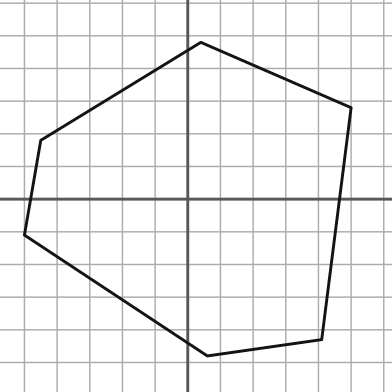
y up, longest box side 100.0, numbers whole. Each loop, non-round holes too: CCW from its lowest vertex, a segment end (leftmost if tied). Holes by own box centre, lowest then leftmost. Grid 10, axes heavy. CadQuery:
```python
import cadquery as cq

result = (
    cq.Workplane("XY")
    .moveTo(6.0, -48.0)
    .lineTo(41.0, -43.0)
    .lineTo(50.0, 28.0)
    .lineTo(4.0, 48.0)
    .lineTo(-45.0, 18.0)
    .lineTo(-50.0, -11.0)
    .close()
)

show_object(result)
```